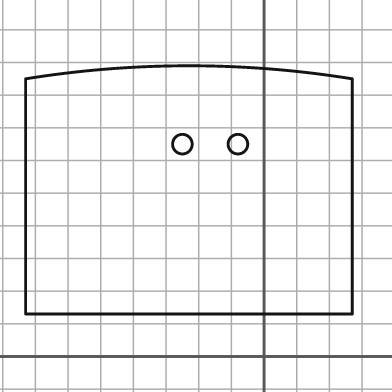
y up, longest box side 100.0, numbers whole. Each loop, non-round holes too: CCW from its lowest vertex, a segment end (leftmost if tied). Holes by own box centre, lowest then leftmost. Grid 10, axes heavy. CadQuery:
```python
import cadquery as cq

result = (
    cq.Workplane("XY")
    .moveTo(-73.0, 13.0)
    .lineTo(27.0, 13.0)
    .lineTo(27.0, 85.0)
    .threePointArc((-23.0, 89.0), (-73.0, 85.0))
    .close()
    .moveTo(-25.0, 65.0)
    .circle(3.0)
    .moveTo(-8.0, 65.0)
    .circle(3.0)
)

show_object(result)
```